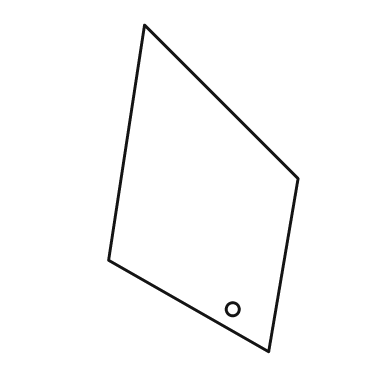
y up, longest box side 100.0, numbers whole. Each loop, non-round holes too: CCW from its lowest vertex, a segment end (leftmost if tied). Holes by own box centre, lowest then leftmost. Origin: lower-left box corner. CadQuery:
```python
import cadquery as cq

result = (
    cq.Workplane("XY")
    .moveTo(49.0, 0.0)
    .lineTo(58.0, 53.0)
    .lineTo(11.0, 100.0)
    .lineTo(0.0, 28.0)
    .close()
    .moveTo(38.0, 13.0)
    .circle(2.0)
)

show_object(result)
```